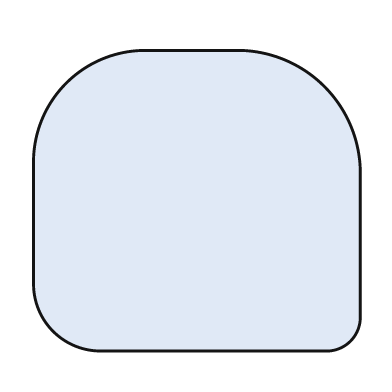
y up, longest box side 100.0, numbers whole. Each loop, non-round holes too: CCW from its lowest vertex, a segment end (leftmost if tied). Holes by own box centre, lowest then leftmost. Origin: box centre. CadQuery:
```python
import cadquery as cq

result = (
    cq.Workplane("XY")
    .moveTo(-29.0, -46.0)
    .lineTo(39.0, -46.0)
    .threePointArc((47.0, -43.0), (50.0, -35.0))
    .lineTo(50.0, 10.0)
    .threePointArc((39.0, 35.0), (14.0, 46.0))
    .lineTo(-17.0, 46.0)
    .threePointArc((-40.0, 36.0), (-50.0, 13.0))
    .lineTo(-50.0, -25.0)
    .threePointArc((-44.0, -40.0), (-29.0, -46.0))
    .close()
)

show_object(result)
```